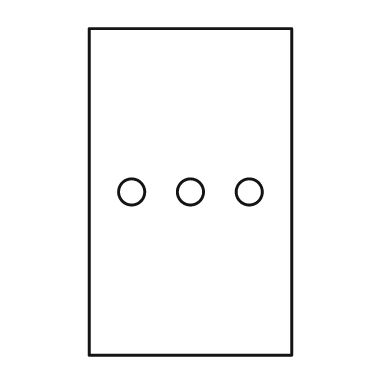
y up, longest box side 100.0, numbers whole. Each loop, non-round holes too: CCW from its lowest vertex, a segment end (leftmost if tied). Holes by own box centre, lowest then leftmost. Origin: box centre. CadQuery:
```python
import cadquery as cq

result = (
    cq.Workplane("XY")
    .moveTo(-31.0, -50.0)
    .lineTo(31.0, -50.0)
    .lineTo(31.0, 50.0)
    .lineTo(-31.0, 50.0)
    .close()
    .moveTo(-18.0, 0.0)
    .circle(4.0)
    .moveTo(0.0, 0.0)
    .circle(4.0)
    .moveTo(18.0, 0.0)
    .circle(4.0)
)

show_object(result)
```